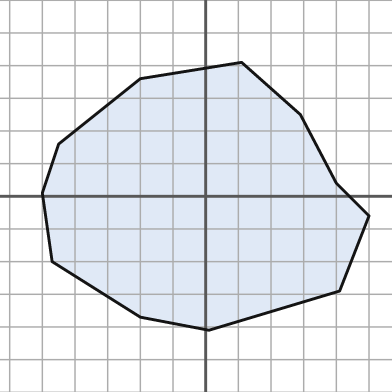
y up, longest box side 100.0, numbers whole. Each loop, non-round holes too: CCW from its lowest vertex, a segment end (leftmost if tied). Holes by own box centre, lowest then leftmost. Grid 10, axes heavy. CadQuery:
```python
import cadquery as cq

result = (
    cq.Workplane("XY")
    .moveTo(1.0, -41.0)
    .lineTo(41.0, -29.0)
    .lineTo(50.0, -6.0)
    .lineTo(40.0, 4.0)
    .lineTo(29.0, 25.0)
    .lineTo(11.0, 41.0)
    .lineTo(-20.0, 36.0)
    .lineTo(-45.0, 16.0)
    .lineTo(-50.0, 1.0)
    .lineTo(-47.0, -20.0)
    .lineTo(-20.0, -37.0)
    .close()
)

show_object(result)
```